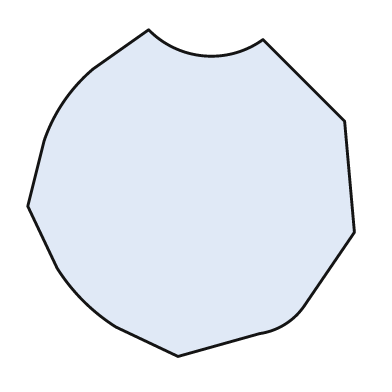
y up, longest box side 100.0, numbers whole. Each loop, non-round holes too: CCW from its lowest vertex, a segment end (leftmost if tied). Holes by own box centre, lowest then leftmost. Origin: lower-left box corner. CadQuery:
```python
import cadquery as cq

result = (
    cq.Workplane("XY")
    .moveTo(46.0, 0.0)
    .lineTo(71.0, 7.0)
    .threePointArc((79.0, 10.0), (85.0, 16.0))
    .lineTo(100.0, 38.0)
    .lineTo(97.0, 72.0)
    .lineTo(72.0, 97.0)
    .threePointArc((54.0, 92.0), (37.0, 100.0))
    .lineTo(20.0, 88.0)
    .threePointArc((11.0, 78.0), (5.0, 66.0))
    .lineTo(0.0, 46.0)
    .lineTo(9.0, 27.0)
    .threePointArc((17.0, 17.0), (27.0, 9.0))
    .close()
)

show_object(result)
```